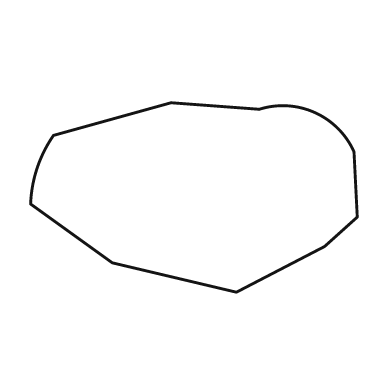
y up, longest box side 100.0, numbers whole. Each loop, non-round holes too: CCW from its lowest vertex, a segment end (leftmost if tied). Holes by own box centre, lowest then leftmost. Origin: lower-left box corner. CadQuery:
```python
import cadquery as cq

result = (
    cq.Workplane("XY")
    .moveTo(63.0, 0.0)
    .lineTo(90.0, 14.0)
    .lineTo(100.0, 23.0)
    .lineTo(99.0, 43.0)
    .threePointArc((87.0, 55.0), (70.0, 56.0))
    .lineTo(43.0, 58.0)
    .lineTo(7.0, 48.0)
    .threePointArc((2.0, 38.0), (0.0, 27.0))
    .lineTo(25.0, 9.0)
    .close()
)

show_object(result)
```